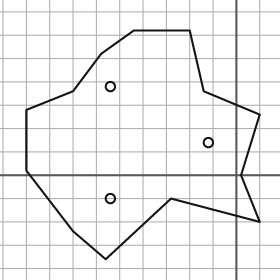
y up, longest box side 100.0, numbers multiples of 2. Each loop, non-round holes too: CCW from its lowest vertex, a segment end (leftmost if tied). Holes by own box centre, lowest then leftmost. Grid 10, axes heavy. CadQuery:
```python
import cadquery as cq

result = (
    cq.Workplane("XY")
    .moveTo(-56.0, -36.0)
    .lineTo(-28.0, -10.0)
    .lineTo(10.0, -20.0)
    .lineTo(2.0, 0.0)
    .lineTo(10.0, 26.0)
    .lineTo(-14.0, 36.0)
    .lineTo(-20.0, 62.0)
    .lineTo(-44.0, 62.0)
    .lineTo(-58.0, 52.0)
    .lineTo(-70.0, 36.0)
    .lineTo(-90.0, 28.0)
    .lineTo(-90.0, 2.0)
    .lineTo(-70.0, -24.0)
    .close()
    .moveTo(-54.0, -10.0)
    .circle(2.0)
    .moveTo(-12.0, 14.0)
    .circle(2.0)
    .moveTo(-54.0, 38.0)
    .circle(2.0)
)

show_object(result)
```